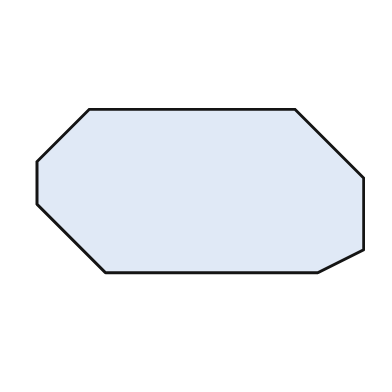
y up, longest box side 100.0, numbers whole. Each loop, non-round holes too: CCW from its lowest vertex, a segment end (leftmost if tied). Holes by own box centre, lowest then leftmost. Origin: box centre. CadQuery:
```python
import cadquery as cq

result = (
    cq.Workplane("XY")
    .moveTo(-29.0, -25.0)
    .lineTo(36.0, -25.0)
    .lineTo(50.0, -18.0)
    .lineTo(50.0, 4.0)
    .lineTo(29.0, 25.0)
    .lineTo(-34.0, 25.0)
    .lineTo(-50.0, 9.0)
    .lineTo(-50.0, -4.0)
    .close()
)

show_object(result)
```